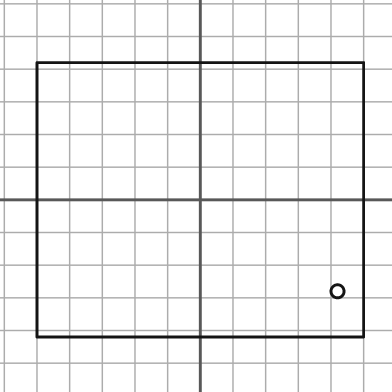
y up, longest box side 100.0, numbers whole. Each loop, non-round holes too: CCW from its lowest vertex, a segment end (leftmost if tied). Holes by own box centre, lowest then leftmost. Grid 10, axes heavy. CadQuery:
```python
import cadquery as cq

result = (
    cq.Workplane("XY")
    .moveTo(-50.0, -42.0)
    .lineTo(50.0, -42.0)
    .lineTo(50.0, 42.0)
    .lineTo(-50.0, 42.0)
    .close()
    .moveTo(42.0, -28.0)
    .circle(2.0)
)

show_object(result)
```